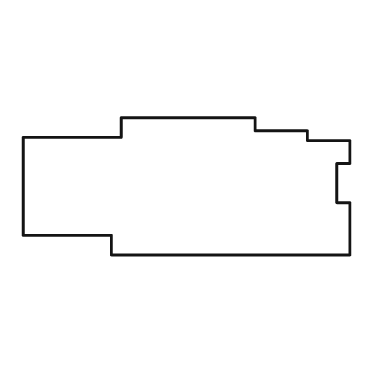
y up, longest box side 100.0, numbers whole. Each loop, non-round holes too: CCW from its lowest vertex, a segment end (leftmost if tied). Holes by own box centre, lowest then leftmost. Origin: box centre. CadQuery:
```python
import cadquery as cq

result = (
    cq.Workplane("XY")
    .moveTo(-23.0, -21.0)
    .lineTo(50.0, -21.0)
    .lineTo(50.0, -5.0)
    .lineTo(46.0, -5.0)
    .lineTo(46.0, 7.0)
    .lineTo(50.0, 7.0)
    .lineTo(50.0, 14.0)
    .lineTo(37.0, 14.0)
    .lineTo(37.0, 17.0)
    .lineTo(21.0, 17.0)
    .lineTo(21.0, 21.0)
    .lineTo(-20.0, 21.0)
    .lineTo(-20.0, 15.0)
    .lineTo(-50.0, 15.0)
    .lineTo(-50.0, -15.0)
    .lineTo(-23.0, -15.0)
    .close()
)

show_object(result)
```